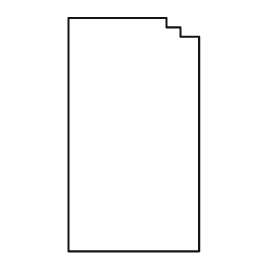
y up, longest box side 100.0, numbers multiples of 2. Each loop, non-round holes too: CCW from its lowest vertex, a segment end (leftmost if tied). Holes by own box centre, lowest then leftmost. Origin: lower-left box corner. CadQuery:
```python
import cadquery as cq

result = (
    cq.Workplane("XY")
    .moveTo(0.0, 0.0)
    .lineTo(56.0, 0.0)
    .lineTo(56.0, 92.0)
    .lineTo(48.0, 92.0)
    .lineTo(48.0, 96.0)
    .lineTo(42.0, 96.0)
    .lineTo(42.0, 100.0)
    .lineTo(0.0, 100.0)
    .close()
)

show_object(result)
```